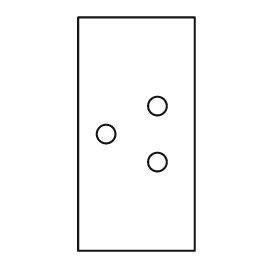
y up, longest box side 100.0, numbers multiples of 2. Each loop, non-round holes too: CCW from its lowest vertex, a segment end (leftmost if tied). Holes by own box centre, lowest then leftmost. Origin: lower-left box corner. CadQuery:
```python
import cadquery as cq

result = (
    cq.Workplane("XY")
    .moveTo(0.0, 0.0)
    .lineTo(50.0, 0.0)
    .lineTo(50.0, 100.0)
    .lineTo(0.0, 100.0)
    .close()
    .moveTo(34.0, 38.0)
    .circle(4.0)
    .moveTo(12.0, 50.0)
    .circle(4.0)
    .moveTo(34.0, 62.0)
    .circle(4.0)
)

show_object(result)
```